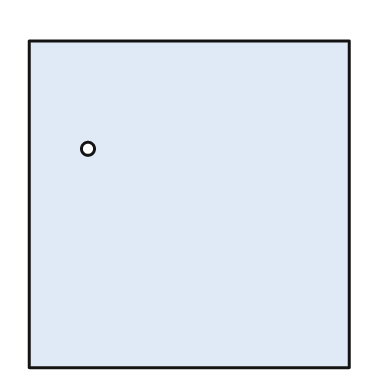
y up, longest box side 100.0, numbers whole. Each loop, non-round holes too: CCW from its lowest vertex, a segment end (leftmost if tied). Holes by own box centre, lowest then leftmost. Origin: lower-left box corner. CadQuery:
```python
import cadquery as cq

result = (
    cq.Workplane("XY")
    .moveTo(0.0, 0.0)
    .lineTo(98.0, 0.0)
    .lineTo(98.0, 100.0)
    .lineTo(0.0, 100.0)
    .close()
    .moveTo(18.0, 67.0)
    .circle(2.0)
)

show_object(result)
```